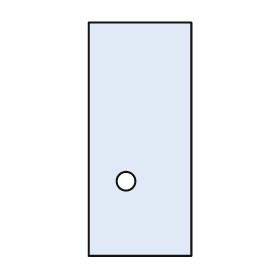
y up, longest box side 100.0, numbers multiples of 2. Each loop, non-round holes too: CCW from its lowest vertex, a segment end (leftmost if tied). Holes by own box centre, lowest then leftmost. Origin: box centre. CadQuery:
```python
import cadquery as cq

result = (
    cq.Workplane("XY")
    .moveTo(-22.0, -50.0)
    .lineTo(22.0, -50.0)
    .lineTo(22.0, 50.0)
    .lineTo(-22.0, 50.0)
    .close()
    .moveTo(-6.0, -18.0)
    .circle(4.0)
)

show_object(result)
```